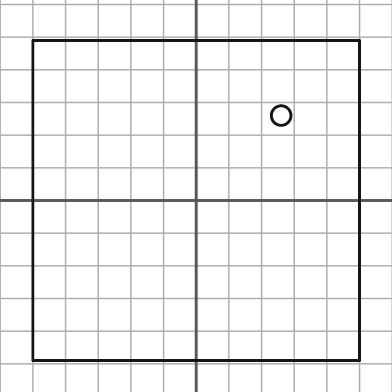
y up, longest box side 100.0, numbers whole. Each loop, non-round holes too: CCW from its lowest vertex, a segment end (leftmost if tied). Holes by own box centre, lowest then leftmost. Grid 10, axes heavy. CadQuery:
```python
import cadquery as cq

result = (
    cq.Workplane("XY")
    .moveTo(-50.0, -49.0)
    .lineTo(50.0, -49.0)
    .lineTo(50.0, 49.0)
    .lineTo(-50.0, 49.0)
    .close()
    .moveTo(26.0, 26.0)
    .circle(3.0)
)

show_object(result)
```